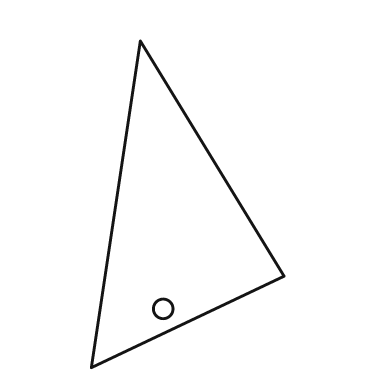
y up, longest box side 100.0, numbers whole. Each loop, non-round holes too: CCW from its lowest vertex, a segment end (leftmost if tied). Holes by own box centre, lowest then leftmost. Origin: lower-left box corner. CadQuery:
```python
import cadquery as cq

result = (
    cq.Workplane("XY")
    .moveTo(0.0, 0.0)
    .lineTo(59.0, 28.0)
    .lineTo(15.0, 100.0)
    .close()
    .moveTo(22.0, 18.0)
    .circle(3.0)
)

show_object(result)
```